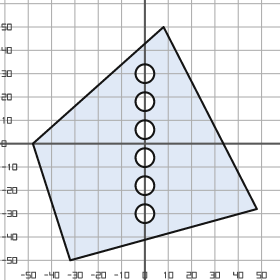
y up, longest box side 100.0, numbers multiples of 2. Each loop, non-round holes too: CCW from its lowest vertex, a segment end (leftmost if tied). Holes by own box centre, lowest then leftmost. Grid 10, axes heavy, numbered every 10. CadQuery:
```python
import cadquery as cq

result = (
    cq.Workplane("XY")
    .moveTo(-32.0, -50.0)
    .lineTo(48.0, -28.0)
    .lineTo(8.0, 50.0)
    .lineTo(-48.0, 0.0)
    .close()
    .moveTo(0.0, -30.0)
    .circle(4.0)
    .moveTo(0.0, -18.0)
    .circle(4.0)
    .moveTo(0.0, -6.0)
    .circle(4.0)
    .moveTo(0.0, 6.0)
    .circle(4.0)
    .moveTo(0.0, 18.0)
    .circle(4.0)
    .moveTo(0.0, 30.0)
    .circle(4.0)
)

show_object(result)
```